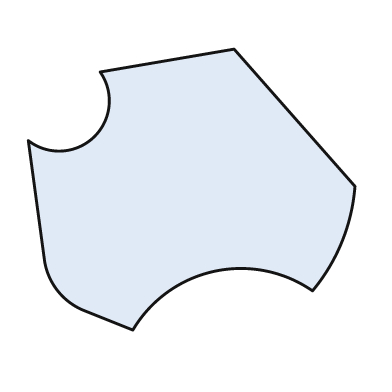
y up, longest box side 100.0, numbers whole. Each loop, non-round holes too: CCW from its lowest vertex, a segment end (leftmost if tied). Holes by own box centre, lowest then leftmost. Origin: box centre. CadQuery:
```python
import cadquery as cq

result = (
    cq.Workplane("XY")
    .moveTo(-18.0, -43.0)
    .threePointArc((7.0, -25.0), (37.0, -31.0))
    .threePointArc((46.0, -16.0), (50.0, 1.0))
    .lineTo(13.0, 43.0)
    .lineTo(-28.0, 36.0)
    .threePointArc((-30.0, 16.0), (-50.0, 15.0))
    .lineTo(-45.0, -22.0)
    .threePointArc((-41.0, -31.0), (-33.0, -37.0))
    .close()
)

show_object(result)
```